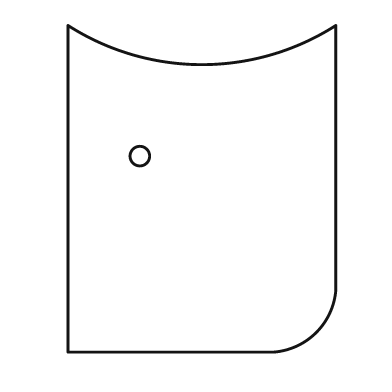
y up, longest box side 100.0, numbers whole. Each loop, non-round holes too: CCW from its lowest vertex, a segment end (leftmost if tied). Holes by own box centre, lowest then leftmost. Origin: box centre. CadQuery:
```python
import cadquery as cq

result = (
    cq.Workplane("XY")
    .moveTo(-41.0, -50.0)
    .lineTo(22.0, -50.0)
    .threePointArc((35.0, -44.0), (41.0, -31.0))
    .lineTo(41.0, 50.0)
    .threePointArc((0.0, 38.0), (-41.0, 50.0))
    .close()
    .moveTo(-19.0, 10.0)
    .circle(3.0)
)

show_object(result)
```